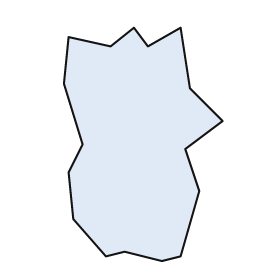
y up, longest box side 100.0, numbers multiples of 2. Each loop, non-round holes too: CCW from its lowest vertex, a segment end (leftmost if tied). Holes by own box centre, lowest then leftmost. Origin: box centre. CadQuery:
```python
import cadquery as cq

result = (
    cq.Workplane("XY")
    .moveTo(8.0, -50.0)
    .lineTo(16.0, -48.0)
    .lineTo(24.0, -20.0)
    .lineTo(18.0, -2.0)
    .lineTo(34.0, 10.0)
    .lineTo(20.0, 24.0)
    .lineTo(16.0, 50.0)
    .lineTo(2.0, 42.0)
    .lineTo(-4.0, 50.0)
    .lineTo(-14.0, 42.0)
    .lineTo(-32.0, 46.0)
    .lineTo(-34.0, 26.0)
    .lineTo(-26.0, 0.0)
    .lineTo(-32.0, -12.0)
    .lineTo(-30.0, -32.0)
    .lineTo(-16.0, -48.0)
    .lineTo(-8.0, -46.0)
    .close()
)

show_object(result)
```